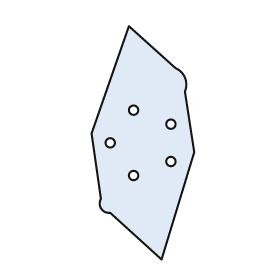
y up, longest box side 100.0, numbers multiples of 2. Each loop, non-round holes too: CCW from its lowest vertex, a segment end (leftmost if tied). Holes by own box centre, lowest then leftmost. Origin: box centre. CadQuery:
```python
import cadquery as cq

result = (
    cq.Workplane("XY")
    .moveTo(8.0, -50.0)
    .lineTo(22.0, -4.0)
    .lineTo(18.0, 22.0)
    .threePointArc((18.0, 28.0), (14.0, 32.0))
    .lineTo(-6.0, 50.0)
    .lineTo(-22.0, 4.0)
    .lineTo(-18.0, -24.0)
    .threePointArc((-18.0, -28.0), (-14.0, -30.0))
    .close()
    .moveTo(-4.0, -14.0)
    .circle(2.0)
    .moveTo(12.0, -8.0)
    .circle(2.0)
    .moveTo(-14.0, 0.0)
    .circle(2.0)
    .moveTo(12.0, 8.0)
    .circle(2.0)
    .moveTo(-4.0, 14.0)
    .circle(2.0)
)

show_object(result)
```